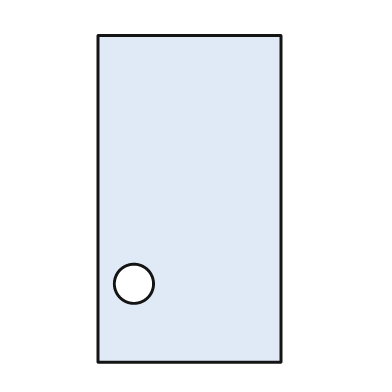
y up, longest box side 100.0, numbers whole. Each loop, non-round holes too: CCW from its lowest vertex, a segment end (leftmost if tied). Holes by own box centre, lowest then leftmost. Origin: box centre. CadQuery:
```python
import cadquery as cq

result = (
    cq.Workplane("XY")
    .moveTo(-28.0, -50.0)
    .lineTo(28.0, -50.0)
    .lineTo(28.0, 50.0)
    .lineTo(-28.0, 50.0)
    .close()
    .moveTo(-17.0, -26.0)
    .circle(6.0)
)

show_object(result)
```